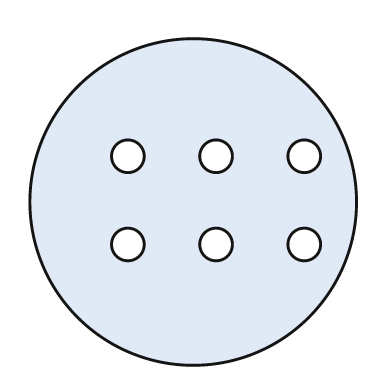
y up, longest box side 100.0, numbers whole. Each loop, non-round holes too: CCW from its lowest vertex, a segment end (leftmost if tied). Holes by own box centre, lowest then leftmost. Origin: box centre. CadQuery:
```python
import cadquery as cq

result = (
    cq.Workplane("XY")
    .moveTo(0.0, 0.0)
    .circle(50.0)
    .moveTo(-20.0, -13.0)
    .circle(5.0)
    .moveTo(7.0, -13.0)
    .circle(5.0)
    .moveTo(34.0, -13.0)
    .circle(5.0)
    .moveTo(-20.0, 14.0)
    .circle(5.0)
    .moveTo(7.0, 14.0)
    .circle(5.0)
    .moveTo(34.0, 14.0)
    .circle(5.0)
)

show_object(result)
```